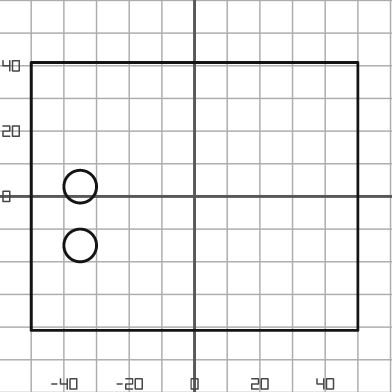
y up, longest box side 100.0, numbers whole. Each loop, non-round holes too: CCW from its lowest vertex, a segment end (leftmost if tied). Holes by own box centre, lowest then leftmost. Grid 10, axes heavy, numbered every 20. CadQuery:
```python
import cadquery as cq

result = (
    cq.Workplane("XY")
    .moveTo(-50.0, -41.0)
    .lineTo(50.0, -41.0)
    .lineTo(50.0, 41.0)
    .lineTo(-50.0, 41.0)
    .close()
    .moveTo(-35.0, -15.0)
    .circle(5.0)
    .moveTo(-35.0, 3.0)
    .circle(5.0)
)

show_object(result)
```